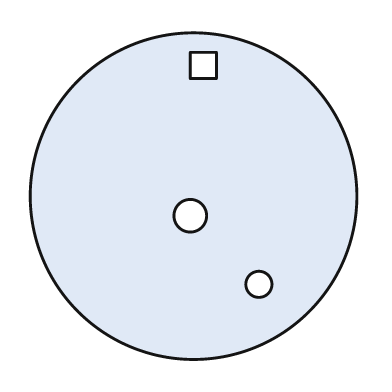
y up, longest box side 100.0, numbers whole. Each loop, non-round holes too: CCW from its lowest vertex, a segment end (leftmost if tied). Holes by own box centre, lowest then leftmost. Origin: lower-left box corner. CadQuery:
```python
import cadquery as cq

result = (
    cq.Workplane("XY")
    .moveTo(50.0, 50.0)
    .circle(50.0)
    .moveTo(70.0, 23.0)
    .circle(4.0)
    .moveTo(49.0, 44.0)
    .circle(5.0)
    .moveTo(49.0, 86.0)
    .lineTo(57.0, 86.0)
    .lineTo(57.0, 94.0)
    .lineTo(49.0, 94.0)
    .close()
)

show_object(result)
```